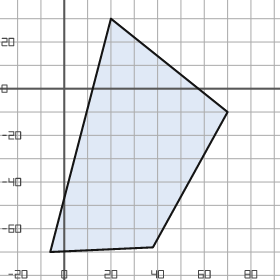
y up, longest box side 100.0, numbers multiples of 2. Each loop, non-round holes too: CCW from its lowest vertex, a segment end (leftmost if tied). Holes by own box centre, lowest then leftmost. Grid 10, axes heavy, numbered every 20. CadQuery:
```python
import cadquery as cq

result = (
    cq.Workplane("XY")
    .moveTo(-6.0, -70.0)
    .lineTo(38.0, -68.0)
    .lineTo(70.0, -10.0)
    .lineTo(20.0, 30.0)
    .close()
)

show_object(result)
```